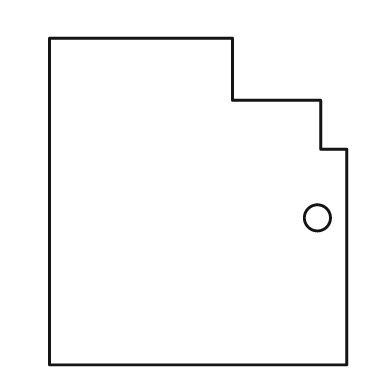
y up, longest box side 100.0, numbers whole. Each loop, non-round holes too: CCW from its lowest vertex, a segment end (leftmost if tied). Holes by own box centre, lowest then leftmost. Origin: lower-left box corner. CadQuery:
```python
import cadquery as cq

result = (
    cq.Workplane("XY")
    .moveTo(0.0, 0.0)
    .lineTo(91.0, 0.0)
    .lineTo(91.0, 66.0)
    .lineTo(83.0, 66.0)
    .lineTo(83.0, 81.0)
    .lineTo(56.0, 81.0)
    .lineTo(56.0, 100.0)
    .lineTo(0.0, 100.0)
    .close()
    .moveTo(82.0, 45.0)
    .circle(4.0)
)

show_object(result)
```